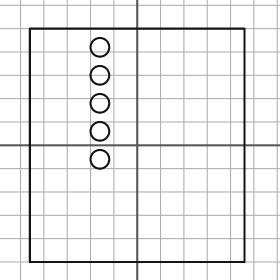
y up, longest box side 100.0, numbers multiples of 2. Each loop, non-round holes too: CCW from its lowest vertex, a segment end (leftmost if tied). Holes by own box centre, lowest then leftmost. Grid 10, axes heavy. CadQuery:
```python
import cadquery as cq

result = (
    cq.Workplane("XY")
    .moveTo(-46.0, -50.0)
    .lineTo(46.0, -50.0)
    .lineTo(46.0, 50.0)
    .lineTo(-46.0, 50.0)
    .close()
    .moveTo(-16.0, -6.0)
    .circle(4.0)
    .moveTo(-16.0, 6.0)
    .circle(4.0)
    .moveTo(-16.0, 18.0)
    .circle(4.0)
    .moveTo(-16.0, 30.0)
    .circle(4.0)
    .moveTo(-16.0, 42.0)
    .circle(4.0)
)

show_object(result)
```